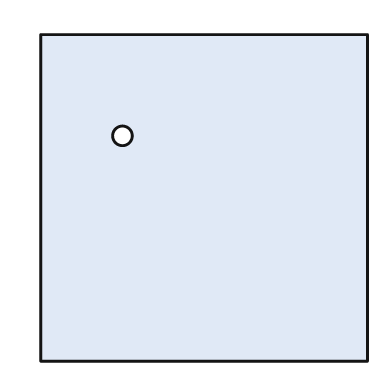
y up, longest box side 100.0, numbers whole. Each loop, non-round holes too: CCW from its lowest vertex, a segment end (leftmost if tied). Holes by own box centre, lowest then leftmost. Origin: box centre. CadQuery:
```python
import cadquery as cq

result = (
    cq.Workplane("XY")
    .moveTo(-50.0, -50.0)
    .lineTo(50.0, -50.0)
    .lineTo(50.0, 50.0)
    .lineTo(-50.0, 50.0)
    .close()
    .moveTo(-25.0, 19.0)
    .circle(3.0)
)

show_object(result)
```